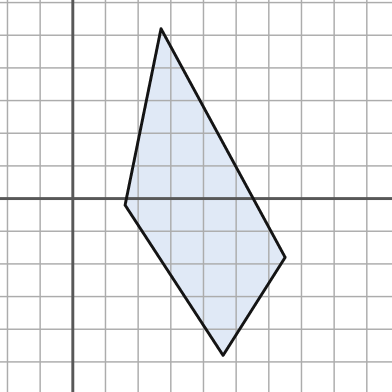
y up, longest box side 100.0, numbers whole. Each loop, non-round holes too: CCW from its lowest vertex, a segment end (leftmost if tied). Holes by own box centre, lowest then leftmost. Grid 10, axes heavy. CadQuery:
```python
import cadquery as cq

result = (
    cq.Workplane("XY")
    .moveTo(46.0, -48.0)
    .lineTo(65.0, -18.0)
    .lineTo(27.0, 52.0)
    .lineTo(16.0, -2.0)
    .close()
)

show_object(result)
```